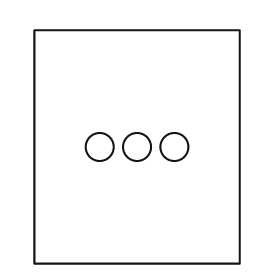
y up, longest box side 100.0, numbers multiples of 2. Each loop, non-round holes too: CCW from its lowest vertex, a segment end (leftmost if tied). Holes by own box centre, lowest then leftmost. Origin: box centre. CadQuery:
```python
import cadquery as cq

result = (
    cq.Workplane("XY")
    .moveTo(-44.0, -50.0)
    .lineTo(44.0, -50.0)
    .lineTo(44.0, 50.0)
    .lineTo(-44.0, 50.0)
    .close()
    .moveTo(-16.0, 0.0)
    .circle(6.0)
    .moveTo(0.0, 0.0)
    .circle(6.0)
    .moveTo(16.0, 0.0)
    .circle(6.0)
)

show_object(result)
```